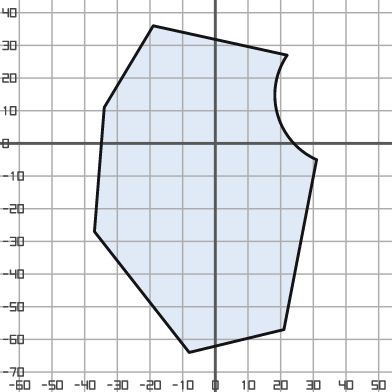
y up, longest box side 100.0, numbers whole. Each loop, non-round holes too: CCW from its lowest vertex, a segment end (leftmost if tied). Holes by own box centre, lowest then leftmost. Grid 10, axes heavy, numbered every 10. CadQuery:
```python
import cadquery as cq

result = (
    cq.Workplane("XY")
    .moveTo(-8.0, -64.0)
    .lineTo(21.0, -57.0)
    .lineTo(31.0, -5.0)
    .threePointArc((19.0, 9.0), (22.0, 27.0))
    .lineTo(-19.0, 36.0)
    .lineTo(-34.0, 11.0)
    .lineTo(-37.0, -27.0)
    .close()
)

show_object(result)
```